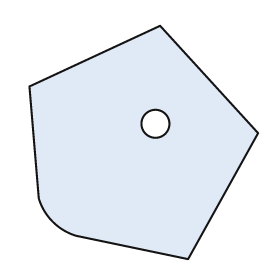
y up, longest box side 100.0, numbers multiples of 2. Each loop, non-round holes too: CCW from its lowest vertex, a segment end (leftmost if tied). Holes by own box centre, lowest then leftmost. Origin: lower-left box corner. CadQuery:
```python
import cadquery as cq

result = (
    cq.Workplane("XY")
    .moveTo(68.0, 0.0)
    .lineTo(98.0, 54.0)
    .lineTo(56.0, 100.0)
    .lineTo(0.0, 74.0)
    .lineTo(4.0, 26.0)
    .threePointArc((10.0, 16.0), (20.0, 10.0))
    .close()
    .moveTo(54.0, 58.0)
    .circle(6.0)
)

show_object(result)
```